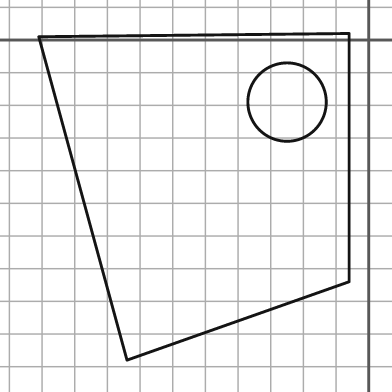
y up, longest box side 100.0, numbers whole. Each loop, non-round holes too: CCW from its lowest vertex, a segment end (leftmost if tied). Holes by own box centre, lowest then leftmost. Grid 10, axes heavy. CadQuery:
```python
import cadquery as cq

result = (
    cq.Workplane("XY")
    .moveTo(-74.0, -98.0)
    .lineTo(-6.0, -74.0)
    .lineTo(-6.0, 2.0)
    .lineTo(-101.0, 1.0)
    .close()
    .moveTo(-25.0, -19.0)
    .circle(12.0)
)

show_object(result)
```